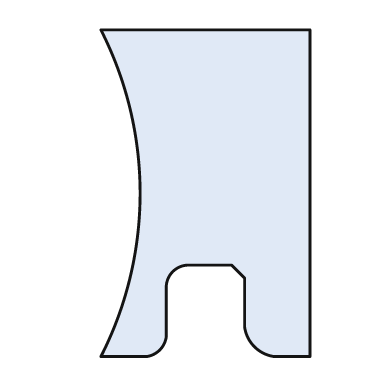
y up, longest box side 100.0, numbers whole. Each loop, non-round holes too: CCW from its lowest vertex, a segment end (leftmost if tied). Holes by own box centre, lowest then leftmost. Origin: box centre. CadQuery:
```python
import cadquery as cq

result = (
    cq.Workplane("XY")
    .moveTo(-32.0, -50.0)
    .lineTo(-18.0, -50.0)
    .threePointArc((-14.0, -48.0), (-12.0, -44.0))
    .lineTo(-12.0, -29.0)
    .threePointArc((-10.0, -24.0), (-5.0, -22.0))
    .lineTo(8.0, -22.0)
    .lineTo(12.0, -26.0)
    .lineTo(12.0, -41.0)
    .threePointArc((15.0, -47.0), (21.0, -50.0))
    .lineTo(32.0, -50.0)
    .lineTo(32.0, 50.0)
    .lineTo(-32.0, 50.0)
    .threePointArc((-20.0, 0.0), (-32.0, -50.0))
    .close()
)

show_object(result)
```